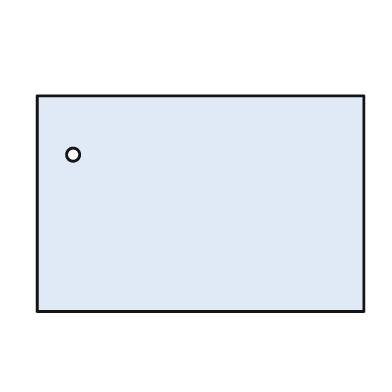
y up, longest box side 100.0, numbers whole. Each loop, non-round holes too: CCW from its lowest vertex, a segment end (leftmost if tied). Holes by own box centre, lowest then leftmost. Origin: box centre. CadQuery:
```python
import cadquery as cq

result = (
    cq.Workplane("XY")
    .moveTo(-50.0, -33.0)
    .lineTo(50.0, -33.0)
    .lineTo(50.0, 33.0)
    .lineTo(-50.0, 33.0)
    .close()
    .moveTo(-39.0, 15.0)
    .circle(2.0)
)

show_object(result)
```